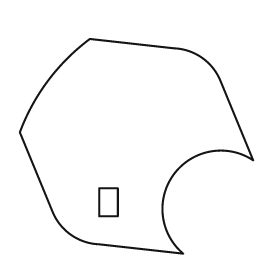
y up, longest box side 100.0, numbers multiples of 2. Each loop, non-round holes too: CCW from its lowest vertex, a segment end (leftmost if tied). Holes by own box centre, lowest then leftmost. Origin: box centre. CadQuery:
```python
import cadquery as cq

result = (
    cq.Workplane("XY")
    .moveTo(20.0, -46.0)
    .threePointArc((16.0, -12.0), (50.0, -6.0))
    .lineTo(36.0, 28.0)
    .threePointArc((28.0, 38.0), (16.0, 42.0))
    .lineTo(-20.0, 46.0)
    .threePointArc((-38.0, 28.0), (-50.0, 6.0))
    .lineTo(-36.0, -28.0)
    .threePointArc((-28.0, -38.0), (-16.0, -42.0))
    .close()
    .moveTo(-16.0, -30.0)
    .lineTo(-8.0, -30.0)
    .lineTo(-8.0, -18.0)
    .lineTo(-16.0, -18.0)
    .close()
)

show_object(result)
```